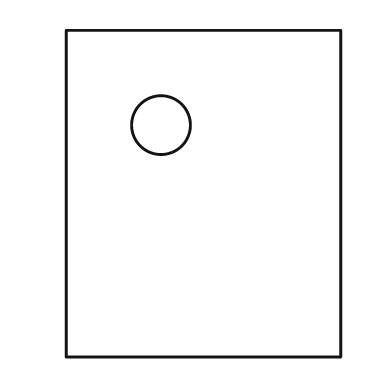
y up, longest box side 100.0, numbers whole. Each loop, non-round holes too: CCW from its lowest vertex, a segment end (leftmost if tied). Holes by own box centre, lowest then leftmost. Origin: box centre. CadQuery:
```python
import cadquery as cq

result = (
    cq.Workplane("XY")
    .moveTo(-42.0, -50.0)
    .lineTo(42.0, -50.0)
    .lineTo(42.0, 50.0)
    .lineTo(-42.0, 50.0)
    .close()
    .moveTo(-13.0, 21.0)
    .circle(9.0)
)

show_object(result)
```